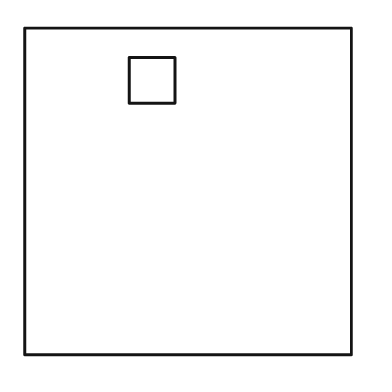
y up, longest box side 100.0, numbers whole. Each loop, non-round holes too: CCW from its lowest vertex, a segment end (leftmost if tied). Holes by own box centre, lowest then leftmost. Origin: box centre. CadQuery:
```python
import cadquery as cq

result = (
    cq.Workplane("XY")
    .moveTo(-50.0, -50.0)
    .lineTo(50.0, -50.0)
    .lineTo(50.0, 50.0)
    .lineTo(-50.0, 50.0)
    .close()
    .moveTo(-18.0, 27.0)
    .lineTo(-4.0, 27.0)
    .lineTo(-4.0, 41.0)
    .lineTo(-18.0, 41.0)
    .close()
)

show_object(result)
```